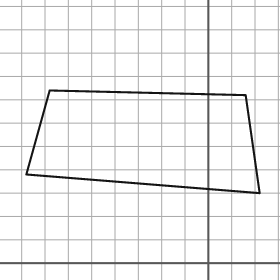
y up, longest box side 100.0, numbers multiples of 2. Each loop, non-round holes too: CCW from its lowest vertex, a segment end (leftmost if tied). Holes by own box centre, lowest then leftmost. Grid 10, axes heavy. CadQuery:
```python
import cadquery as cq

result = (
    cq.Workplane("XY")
    .moveTo(22.0, 30.0)
    .lineTo(16.0, 72.0)
    .lineTo(-68.0, 74.0)
    .lineTo(-78.0, 38.0)
    .close()
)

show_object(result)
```